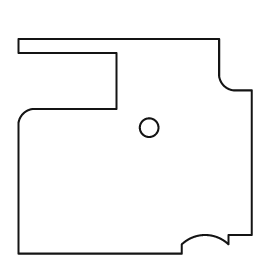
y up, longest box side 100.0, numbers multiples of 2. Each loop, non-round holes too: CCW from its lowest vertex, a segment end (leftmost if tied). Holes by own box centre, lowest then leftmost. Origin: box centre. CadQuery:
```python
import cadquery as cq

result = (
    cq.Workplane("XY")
    .moveTo(-50.0, -46.0)
    .lineTo(20.0, -46.0)
    .lineTo(20.0, -42.0)
    .threePointArc((30.0, -38.0), (40.0, -42.0))
    .lineTo(40.0, -38.0)
    .lineTo(50.0, -38.0)
    .lineTo(50.0, 24.0)
    .lineTo(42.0, 24.0)
    .threePointArc((38.0, 26.0), (36.0, 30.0))
    .lineTo(36.0, 46.0)
    .lineTo(-50.0, 46.0)
    .lineTo(-50.0, 40.0)
    .lineTo(-8.0, 40.0)
    .lineTo(-8.0, 16.0)
    .lineTo(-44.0, 16.0)
    .threePointArc((-48.0, 14.0), (-50.0, 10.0))
    .close()
    .moveTo(6.0, 8.0)
    .circle(4.0)
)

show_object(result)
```